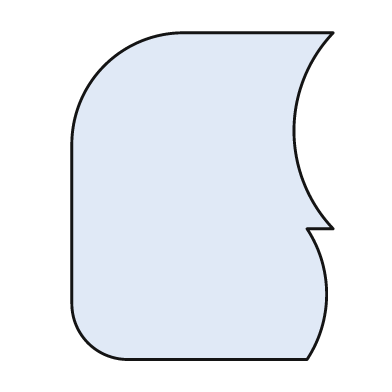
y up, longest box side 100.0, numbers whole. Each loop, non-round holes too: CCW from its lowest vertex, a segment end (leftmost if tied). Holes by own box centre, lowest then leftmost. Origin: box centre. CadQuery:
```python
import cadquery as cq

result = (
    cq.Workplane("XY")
    .moveTo(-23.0, -50.0)
    .lineTo(32.0, -50.0)
    .threePointArc((38.0, -30.0), (32.0, -10.0))
    .lineTo(40.0, -10.0)
    .threePointArc((28.0, 20.0), (40.0, 50.0))
    .lineTo(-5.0, 50.0)
    .threePointArc((-30.0, 40.0), (-40.0, 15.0))
    .lineTo(-40.0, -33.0)
    .threePointArc((-35.0, -45.0), (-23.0, -50.0))
    .close()
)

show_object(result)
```